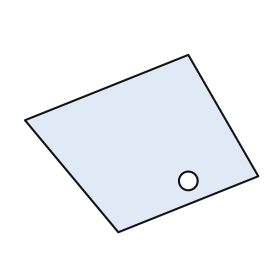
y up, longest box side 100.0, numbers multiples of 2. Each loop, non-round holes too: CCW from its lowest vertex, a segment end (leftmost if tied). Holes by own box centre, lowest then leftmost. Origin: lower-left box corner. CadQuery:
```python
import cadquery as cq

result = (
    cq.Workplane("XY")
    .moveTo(40.0, 0.0)
    .lineTo(100.0, 24.0)
    .lineTo(70.0, 76.0)
    .lineTo(0.0, 48.0)
    .close()
    .moveTo(70.0, 22.0)
    .circle(4.0)
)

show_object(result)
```